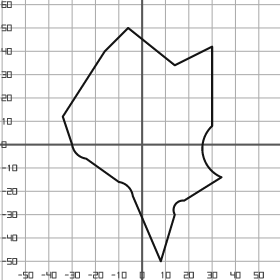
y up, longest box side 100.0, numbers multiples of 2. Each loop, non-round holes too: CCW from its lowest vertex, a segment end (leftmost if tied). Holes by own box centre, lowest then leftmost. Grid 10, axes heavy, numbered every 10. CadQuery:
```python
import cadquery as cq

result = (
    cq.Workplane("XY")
    .moveTo(8.0, -50.0)
    .lineTo(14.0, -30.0)
    .threePointArc((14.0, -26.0), (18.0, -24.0))
    .lineTo(34.0, -14.0)
    .threePointArc((26.0, -4.0), (30.0, 8.0))
    .lineTo(30.0, 42.0)
    .lineTo(14.0, 34.0)
    .lineTo(-6.0, 50.0)
    .lineTo(-16.0, 40.0)
    .lineTo(-34.0, 12.0)
    .lineTo(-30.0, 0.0)
    .threePointArc((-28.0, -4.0), (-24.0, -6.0))
    .lineTo(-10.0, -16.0)
    .threePointArc((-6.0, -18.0), (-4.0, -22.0))
    .close()
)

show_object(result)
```